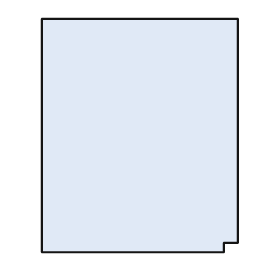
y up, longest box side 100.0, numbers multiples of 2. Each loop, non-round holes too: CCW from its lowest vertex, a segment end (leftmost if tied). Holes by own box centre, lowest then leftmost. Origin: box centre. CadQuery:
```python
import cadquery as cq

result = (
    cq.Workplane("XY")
    .moveTo(-42.0, -50.0)
    .lineTo(36.0, -50.0)
    .lineTo(36.0, -46.0)
    .lineTo(42.0, -46.0)
    .lineTo(42.0, 50.0)
    .lineTo(-42.0, 50.0)
    .close()
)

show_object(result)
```